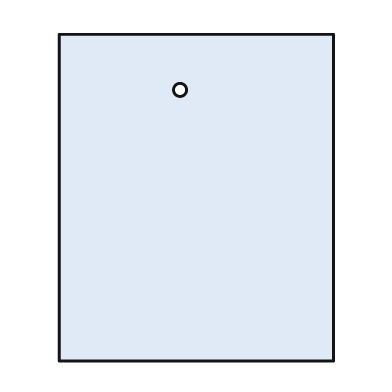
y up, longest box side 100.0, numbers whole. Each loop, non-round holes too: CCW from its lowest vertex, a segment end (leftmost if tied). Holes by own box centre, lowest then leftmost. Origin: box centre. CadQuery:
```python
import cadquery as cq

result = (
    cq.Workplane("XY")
    .moveTo(-42.0, -50.0)
    .lineTo(42.0, -50.0)
    .lineTo(42.0, 50.0)
    .lineTo(-42.0, 50.0)
    .close()
    .moveTo(-5.0, 33.0)
    .circle(2.0)
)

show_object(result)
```